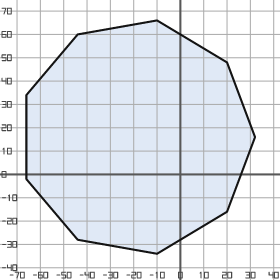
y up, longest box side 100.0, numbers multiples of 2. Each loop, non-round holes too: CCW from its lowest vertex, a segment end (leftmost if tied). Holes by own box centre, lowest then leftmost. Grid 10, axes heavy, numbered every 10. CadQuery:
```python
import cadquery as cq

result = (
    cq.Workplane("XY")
    .moveTo(-10.0, -34.0)
    .lineTo(20.0, -16.0)
    .lineTo(32.0, 16.0)
    .lineTo(20.0, 48.0)
    .lineTo(-10.0, 66.0)
    .lineTo(-44.0, 60.0)
    .lineTo(-66.0, 34.0)
    .lineTo(-66.0, -2.0)
    .lineTo(-44.0, -28.0)
    .close()
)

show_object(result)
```